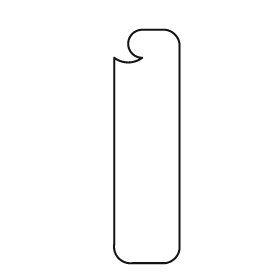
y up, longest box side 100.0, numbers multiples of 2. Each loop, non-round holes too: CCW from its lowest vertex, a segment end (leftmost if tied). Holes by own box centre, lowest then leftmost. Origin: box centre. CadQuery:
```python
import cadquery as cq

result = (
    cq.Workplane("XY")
    .moveTo(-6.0, -50.0)
    .lineTo(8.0, -50.0)
    .threePointArc((12.0, -48.0), (14.0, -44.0))
    .lineTo(14.0, 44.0)
    .threePointArc((12.0, 48.0), (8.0, 50.0))
    .lineTo(-2.0, 50.0)
    .threePointArc((-8.0, 44.0), (-2.0, 38.0))
    .threePointArc((-8.0, 36.0), (-14.0, 38.0))
    .lineTo(-14.0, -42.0)
    .threePointArc((-12.0, -48.0), (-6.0, -50.0))
    .close()
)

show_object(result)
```